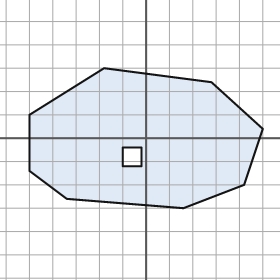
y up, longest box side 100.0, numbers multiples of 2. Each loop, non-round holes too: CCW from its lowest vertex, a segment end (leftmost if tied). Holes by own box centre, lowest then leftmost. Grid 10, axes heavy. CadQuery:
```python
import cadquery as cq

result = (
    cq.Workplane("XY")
    .moveTo(16.0, -30.0)
    .lineTo(42.0, -20.0)
    .lineTo(50.0, 4.0)
    .lineTo(28.0, 24.0)
    .lineTo(-18.0, 30.0)
    .lineTo(-50.0, 10.0)
    .lineTo(-50.0, -14.0)
    .lineTo(-34.0, -26.0)
    .close()
    .moveTo(-10.0, -12.0)
    .lineTo(-2.0, -12.0)
    .lineTo(-2.0, -4.0)
    .lineTo(-10.0, -4.0)
    .close()
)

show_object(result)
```